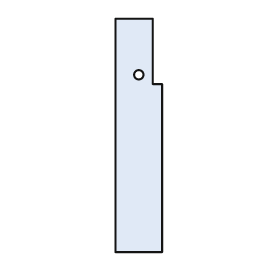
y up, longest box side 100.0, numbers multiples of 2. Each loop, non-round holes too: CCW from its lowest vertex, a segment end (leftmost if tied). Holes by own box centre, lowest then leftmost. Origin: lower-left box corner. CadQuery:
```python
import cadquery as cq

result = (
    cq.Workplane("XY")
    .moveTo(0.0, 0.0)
    .lineTo(20.0, 0.0)
    .lineTo(20.0, 72.0)
    .lineTo(16.0, 72.0)
    .lineTo(16.0, 100.0)
    .lineTo(0.0, 100.0)
    .close()
    .moveTo(10.0, 76.0)
    .circle(2.0)
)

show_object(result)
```